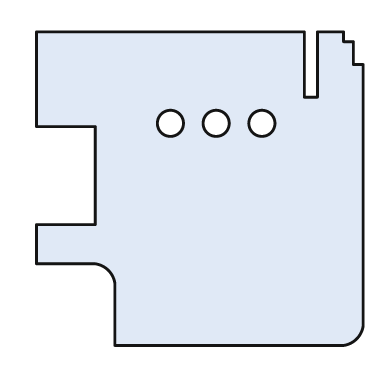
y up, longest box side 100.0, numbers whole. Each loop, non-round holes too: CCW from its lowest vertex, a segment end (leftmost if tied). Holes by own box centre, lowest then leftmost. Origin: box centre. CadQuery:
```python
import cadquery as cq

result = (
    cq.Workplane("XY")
    .moveTo(-26.0, -48.0)
    .lineTo(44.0, -48.0)
    .threePointArc((48.0, -46.0), (50.0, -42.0))
    .lineTo(50.0, 38.0)
    .lineTo(47.0, 38.0)
    .lineTo(47.0, 45.0)
    .lineTo(44.0, 45.0)
    .lineTo(44.0, 48.0)
    .lineTo(36.0, 48.0)
    .lineTo(36.0, 28.0)
    .lineTo(32.0, 28.0)
    .lineTo(32.0, 48.0)
    .lineTo(-50.0, 48.0)
    .lineTo(-50.0, 19.0)
    .lineTo(-32.0, 19.0)
    .lineTo(-32.0, -11.0)
    .lineTo(-50.0, -11.0)
    .lineTo(-50.0, -23.0)
    .lineTo(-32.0, -23.0)
    .threePointArc((-28.0, -25.0), (-26.0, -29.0))
    .close()
    .moveTo(-9.0, 20.0)
    .circle(4.0)
    .moveTo(5.0, 20.0)
    .circle(4.0)
    .moveTo(19.0, 20.0)
    .circle(4.0)
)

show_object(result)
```